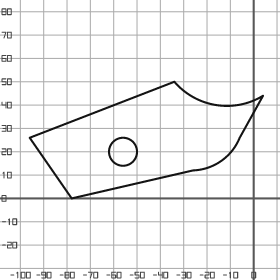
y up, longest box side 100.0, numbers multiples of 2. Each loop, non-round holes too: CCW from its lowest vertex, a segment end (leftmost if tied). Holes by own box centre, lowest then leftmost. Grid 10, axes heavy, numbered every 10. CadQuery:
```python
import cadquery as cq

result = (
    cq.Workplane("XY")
    .moveTo(-78.0, 0.0)
    .lineTo(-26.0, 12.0)
    .threePointArc((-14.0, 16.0), (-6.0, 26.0))
    .lineTo(4.0, 44.0)
    .threePointArc((-16.0, 40.0), (-34.0, 50.0))
    .lineTo(-96.0, 26.0)
    .close()
    .moveTo(-56.0, 20.0)
    .circle(6.0)
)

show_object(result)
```